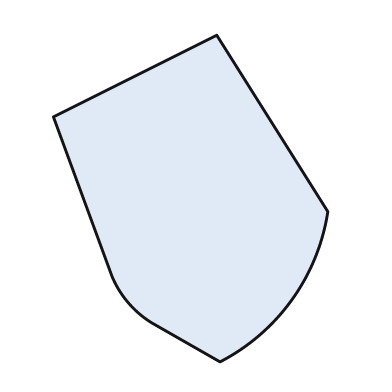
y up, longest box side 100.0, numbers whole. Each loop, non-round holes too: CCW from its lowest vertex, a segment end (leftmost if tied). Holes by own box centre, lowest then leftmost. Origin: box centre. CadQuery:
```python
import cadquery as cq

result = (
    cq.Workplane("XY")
    .moveTo(9.0, -50.0)
    .threePointArc((31.0, -31.0), (42.0, -4.0))
    .lineTo(8.0, 50.0)
    .lineTo(-42.0, 25.0)
    .lineTo(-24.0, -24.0)
    .threePointArc((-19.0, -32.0), (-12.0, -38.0))
    .close()
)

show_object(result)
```